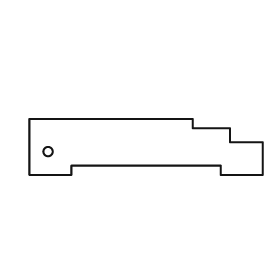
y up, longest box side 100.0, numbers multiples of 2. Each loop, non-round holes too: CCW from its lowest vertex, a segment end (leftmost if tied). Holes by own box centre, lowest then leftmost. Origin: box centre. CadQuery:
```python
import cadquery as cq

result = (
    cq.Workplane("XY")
    .moveTo(-50.0, -12.0)
    .lineTo(-32.0, -12.0)
    .lineTo(-32.0, -8.0)
    .lineTo(32.0, -8.0)
    .lineTo(32.0, -12.0)
    .lineTo(50.0, -12.0)
    .lineTo(50.0, 2.0)
    .lineTo(36.0, 2.0)
    .lineTo(36.0, 8.0)
    .lineTo(20.0, 8.0)
    .lineTo(20.0, 12.0)
    .lineTo(-50.0, 12.0)
    .close()
    .moveTo(-42.0, -2.0)
    .circle(2.0)
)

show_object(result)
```